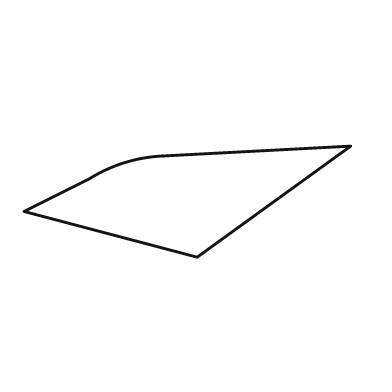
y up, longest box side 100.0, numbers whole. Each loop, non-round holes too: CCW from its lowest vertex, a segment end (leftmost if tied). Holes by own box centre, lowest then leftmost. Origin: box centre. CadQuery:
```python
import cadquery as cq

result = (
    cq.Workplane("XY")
    .moveTo(3.0, -17.0)
    .lineTo(50.0, 17.0)
    .lineTo(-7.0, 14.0)
    .threePointArc((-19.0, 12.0), (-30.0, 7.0))
    .lineTo(-50.0, -3.0)
    .close()
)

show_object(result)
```